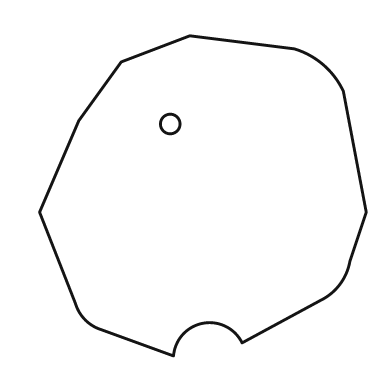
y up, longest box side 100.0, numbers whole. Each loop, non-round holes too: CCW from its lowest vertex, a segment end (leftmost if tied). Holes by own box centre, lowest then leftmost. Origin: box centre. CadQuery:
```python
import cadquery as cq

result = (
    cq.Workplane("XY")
    .moveTo(-9.0, -49.0)
    .threePointArc((0.0, -39.0), (12.0, -45.0))
    .lineTo(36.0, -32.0)
    .threePointArc((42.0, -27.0), (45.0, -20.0))
    .lineTo(50.0, -5.0)
    .lineTo(43.0, 32.0)
    .threePointArc((37.0, 40.0), (28.0, 45.0))
    .lineTo(-4.0, 49.0)
    .lineTo(-25.0, 41.0)
    .lineTo(-38.0, 23.0)
    .lineTo(-50.0, -5.0)
    .lineTo(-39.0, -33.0)
    .threePointArc((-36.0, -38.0), (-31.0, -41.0))
    .close()
    .moveTo(-10.0, 22.0)
    .circle(3.0)
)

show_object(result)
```